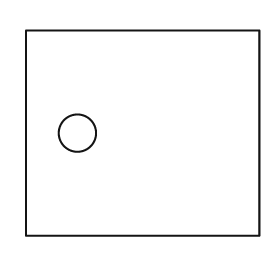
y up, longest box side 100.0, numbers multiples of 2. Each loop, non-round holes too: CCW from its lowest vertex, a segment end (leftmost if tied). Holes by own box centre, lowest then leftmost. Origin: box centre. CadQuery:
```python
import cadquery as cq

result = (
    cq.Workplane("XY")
    .moveTo(-50.0, -44.0)
    .lineTo(50.0, -44.0)
    .lineTo(50.0, 44.0)
    .lineTo(-50.0, 44.0)
    .close()
    .moveTo(-28.0, 0.0)
    .circle(8.0)
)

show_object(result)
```